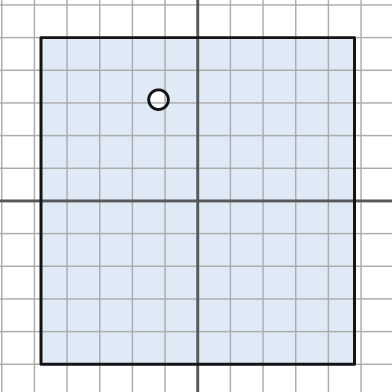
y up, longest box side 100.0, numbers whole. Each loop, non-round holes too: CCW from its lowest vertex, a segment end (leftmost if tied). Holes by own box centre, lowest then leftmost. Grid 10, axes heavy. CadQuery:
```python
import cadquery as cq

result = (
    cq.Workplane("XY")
    .moveTo(-48.0, -50.0)
    .lineTo(48.0, -50.0)
    .lineTo(48.0, 50.0)
    .lineTo(-48.0, 50.0)
    .close()
    .moveTo(-12.0, 31.0)
    .circle(3.0)
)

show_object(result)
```